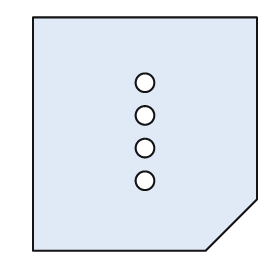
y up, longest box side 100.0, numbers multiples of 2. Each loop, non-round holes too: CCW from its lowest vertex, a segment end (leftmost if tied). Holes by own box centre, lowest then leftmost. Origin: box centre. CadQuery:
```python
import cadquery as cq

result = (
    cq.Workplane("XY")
    .moveTo(-48.0, -50.0)
    .lineTo(26.0, -50.0)
    .lineTo(48.0, -28.0)
    .lineTo(48.0, 50.0)
    .lineTo(-48.0, 50.0)
    .close()
    .moveTo(0.0, -20.0)
    .circle(4.0)
    .moveTo(0.0, -6.0)
    .circle(4.0)
    .moveTo(0.0, 8.0)
    .circle(4.0)
    .moveTo(0.0, 22.0)
    .circle(4.0)
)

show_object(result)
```